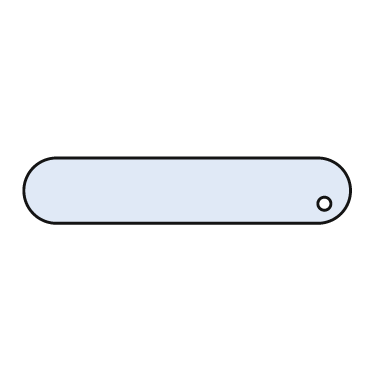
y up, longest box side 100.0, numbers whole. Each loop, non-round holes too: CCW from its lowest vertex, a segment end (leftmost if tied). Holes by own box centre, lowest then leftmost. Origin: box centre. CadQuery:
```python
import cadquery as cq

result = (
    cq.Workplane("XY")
    .moveTo(-40.0, -10.0)
    .lineTo(40.0, -10.0)
    .threePointArc((50.0, 0.0), (40.0, 10.0))
    .lineTo(-40.0, 10.0)
    .threePointArc((-50.0, 0.0), (-40.0, -10.0))
    .close()
    .moveTo(42.0, -4.0)
    .circle(2.0)
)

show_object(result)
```